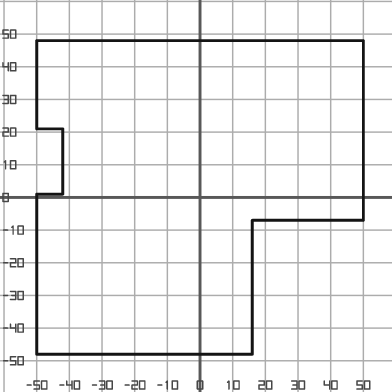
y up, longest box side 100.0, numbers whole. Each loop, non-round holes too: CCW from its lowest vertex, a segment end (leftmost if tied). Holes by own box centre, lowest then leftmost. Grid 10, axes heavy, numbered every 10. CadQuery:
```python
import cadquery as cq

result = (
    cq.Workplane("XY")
    .moveTo(-50.0, -48.0)
    .lineTo(16.0, -48.0)
    .lineTo(16.0, -7.0)
    .lineTo(50.0, -7.0)
    .lineTo(50.0, 48.0)
    .lineTo(-50.0, 48.0)
    .lineTo(-50.0, 21.0)
    .lineTo(-42.0, 21.0)
    .lineTo(-42.0, 1.0)
    .lineTo(-50.0, 1.0)
    .close()
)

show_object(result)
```